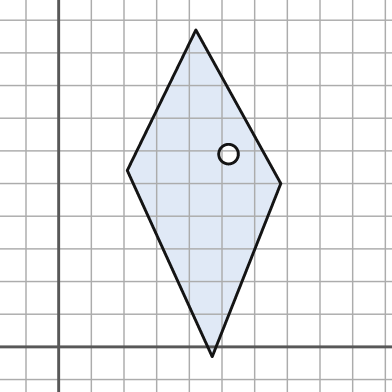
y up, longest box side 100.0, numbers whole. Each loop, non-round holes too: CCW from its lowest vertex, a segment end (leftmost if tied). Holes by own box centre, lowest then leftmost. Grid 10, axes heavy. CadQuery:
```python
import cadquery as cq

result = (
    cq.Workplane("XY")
    .moveTo(47.0, -3.0)
    .lineTo(68.0, 50.0)
    .lineTo(42.0, 97.0)
    .lineTo(21.0, 54.0)
    .close()
    .moveTo(52.0, 59.0)
    .circle(3.0)
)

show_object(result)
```